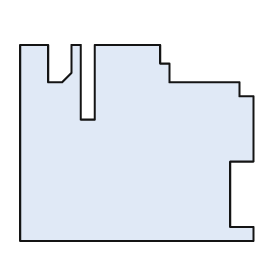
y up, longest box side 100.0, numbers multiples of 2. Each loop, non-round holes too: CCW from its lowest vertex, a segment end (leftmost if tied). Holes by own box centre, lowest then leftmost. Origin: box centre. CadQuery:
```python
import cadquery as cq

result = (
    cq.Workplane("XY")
    .moveTo(-50.0, -42.0)
    .lineTo(50.0, -42.0)
    .lineTo(50.0, -36.0)
    .lineTo(40.0, -36.0)
    .lineTo(40.0, -8.0)
    .lineTo(50.0, -8.0)
    .lineTo(50.0, 20.0)
    .lineTo(44.0, 20.0)
    .lineTo(44.0, 26.0)
    .lineTo(14.0, 26.0)
    .lineTo(14.0, 34.0)
    .lineTo(10.0, 34.0)
    .lineTo(10.0, 42.0)
    .lineTo(-18.0, 42.0)
    .lineTo(-18.0, 10.0)
    .lineTo(-24.0, 10.0)
    .lineTo(-24.0, 42.0)
    .lineTo(-28.0, 42.0)
    .lineTo(-28.0, 30.0)
    .lineTo(-32.0, 26.0)
    .lineTo(-38.0, 26.0)
    .lineTo(-38.0, 42.0)
    .lineTo(-50.0, 42.0)
    .close()
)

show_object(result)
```